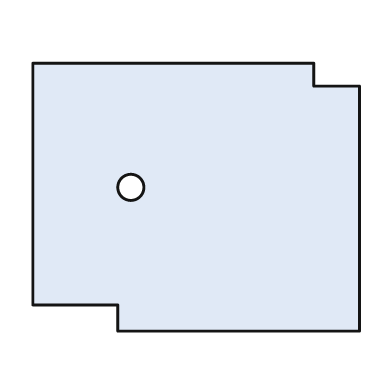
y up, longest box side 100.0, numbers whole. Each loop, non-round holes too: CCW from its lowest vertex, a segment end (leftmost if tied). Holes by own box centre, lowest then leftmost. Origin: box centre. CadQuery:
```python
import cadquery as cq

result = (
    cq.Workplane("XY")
    .moveTo(-24.0, -41.0)
    .lineTo(50.0, -41.0)
    .lineTo(50.0, 34.0)
    .lineTo(36.0, 34.0)
    .lineTo(36.0, 41.0)
    .lineTo(-50.0, 41.0)
    .lineTo(-50.0, -33.0)
    .lineTo(-24.0, -33.0)
    .close()
    .moveTo(-20.0, 3.0)
    .circle(4.0)
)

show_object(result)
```